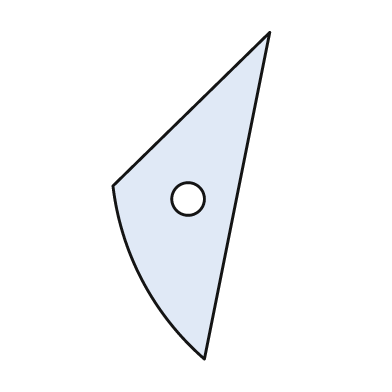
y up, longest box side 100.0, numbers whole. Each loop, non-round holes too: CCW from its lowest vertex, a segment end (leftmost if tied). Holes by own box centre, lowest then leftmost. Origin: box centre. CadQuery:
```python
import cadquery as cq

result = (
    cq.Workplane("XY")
    .moveTo(4.0, -50.0)
    .lineTo(24.0, 50.0)
    .lineTo(-24.0, 3.0)
    .threePointArc((-15.0, -26.0), (4.0, -50.0))
    .close()
    .moveTo(-1.0, -1.0)
    .circle(5.0)
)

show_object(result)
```